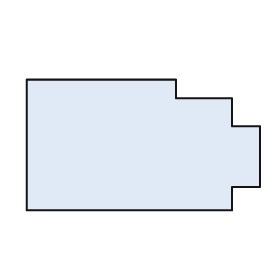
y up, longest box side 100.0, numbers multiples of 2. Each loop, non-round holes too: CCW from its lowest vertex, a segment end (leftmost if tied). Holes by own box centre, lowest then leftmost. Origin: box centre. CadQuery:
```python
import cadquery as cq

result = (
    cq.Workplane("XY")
    .moveTo(-50.0, -28.0)
    .lineTo(38.0, -28.0)
    .lineTo(38.0, -18.0)
    .lineTo(50.0, -18.0)
    .lineTo(50.0, 8.0)
    .lineTo(38.0, 8.0)
    .lineTo(38.0, 20.0)
    .lineTo(14.0, 20.0)
    .lineTo(14.0, 28.0)
    .lineTo(-50.0, 28.0)
    .close()
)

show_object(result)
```